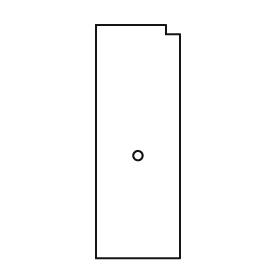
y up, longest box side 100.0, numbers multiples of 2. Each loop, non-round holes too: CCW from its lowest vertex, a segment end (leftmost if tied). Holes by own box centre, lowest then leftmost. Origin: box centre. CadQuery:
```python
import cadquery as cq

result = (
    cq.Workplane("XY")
    .moveTo(-18.0, -50.0)
    .lineTo(18.0, -50.0)
    .lineTo(18.0, 46.0)
    .lineTo(12.0, 46.0)
    .lineTo(12.0, 50.0)
    .lineTo(-18.0, 50.0)
    .close()
    .moveTo(0.0, -6.0)
    .circle(2.0)
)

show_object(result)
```